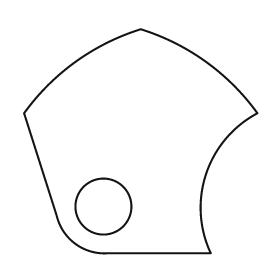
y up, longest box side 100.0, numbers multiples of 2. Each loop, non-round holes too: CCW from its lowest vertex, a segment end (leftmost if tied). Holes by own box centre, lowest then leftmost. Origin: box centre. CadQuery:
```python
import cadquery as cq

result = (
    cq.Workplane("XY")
    .moveTo(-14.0, -48.0)
    .lineTo(30.0, -48.0)
    .threePointArc((28.0, -14.0), (50.0, 12.0))
    .threePointArc((28.0, 34.0), (0.0, 48.0))
    .threePointArc((-28.0, 34.0), (-50.0, 12.0))
    .lineTo(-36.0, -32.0)
    .threePointArc((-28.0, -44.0), (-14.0, -48.0))
    .close()
    .moveTo(-16.0, -28.0)
    .circle(12.0)
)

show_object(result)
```